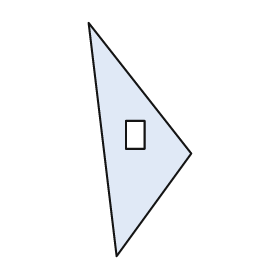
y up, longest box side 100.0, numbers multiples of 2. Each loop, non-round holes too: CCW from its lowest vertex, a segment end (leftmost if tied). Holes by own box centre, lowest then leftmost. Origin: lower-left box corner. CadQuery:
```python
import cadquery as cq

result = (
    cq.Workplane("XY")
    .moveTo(12.0, 0.0)
    .lineTo(44.0, 44.0)
    .lineTo(0.0, 100.0)
    .close()
    .moveTo(16.0, 46.0)
    .lineTo(24.0, 46.0)
    .lineTo(24.0, 58.0)
    .lineTo(16.0, 58.0)
    .close()
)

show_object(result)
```